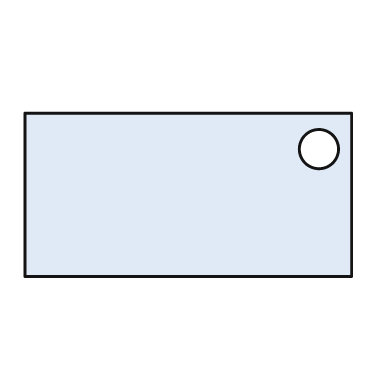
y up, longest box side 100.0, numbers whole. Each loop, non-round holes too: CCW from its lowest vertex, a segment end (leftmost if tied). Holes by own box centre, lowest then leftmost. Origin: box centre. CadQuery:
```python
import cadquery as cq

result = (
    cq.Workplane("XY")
    .moveTo(-50.0, -25.0)
    .lineTo(50.0, -25.0)
    .lineTo(50.0, 25.0)
    .lineTo(-50.0, 25.0)
    .close()
    .moveTo(40.0, 14.0)
    .circle(6.0)
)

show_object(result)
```